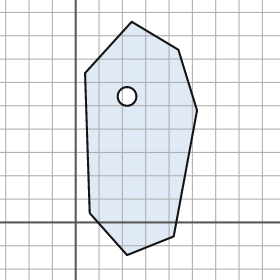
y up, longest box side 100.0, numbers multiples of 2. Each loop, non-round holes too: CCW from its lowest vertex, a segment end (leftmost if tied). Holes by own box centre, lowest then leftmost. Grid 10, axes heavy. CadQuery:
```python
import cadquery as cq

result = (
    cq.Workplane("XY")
    .moveTo(22.0, -14.0)
    .lineTo(42.0, -6.0)
    .lineTo(52.0, 48.0)
    .lineTo(44.0, 74.0)
    .lineTo(24.0, 86.0)
    .lineTo(4.0, 64.0)
    .lineTo(6.0, 4.0)
    .close()
    .moveTo(22.0, 54.0)
    .circle(4.0)
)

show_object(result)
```